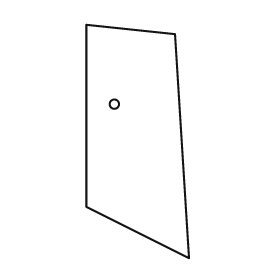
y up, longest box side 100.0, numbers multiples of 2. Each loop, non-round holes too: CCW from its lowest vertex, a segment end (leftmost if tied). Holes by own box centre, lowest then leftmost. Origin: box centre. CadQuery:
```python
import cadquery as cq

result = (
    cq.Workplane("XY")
    .moveTo(22.0, -50.0)
    .lineTo(16.0, 46.0)
    .lineTo(-22.0, 50.0)
    .lineTo(-22.0, -28.0)
    .close()
    .moveTo(-10.0, 16.0)
    .circle(2.0)
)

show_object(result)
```